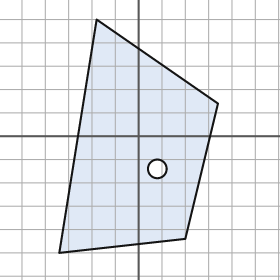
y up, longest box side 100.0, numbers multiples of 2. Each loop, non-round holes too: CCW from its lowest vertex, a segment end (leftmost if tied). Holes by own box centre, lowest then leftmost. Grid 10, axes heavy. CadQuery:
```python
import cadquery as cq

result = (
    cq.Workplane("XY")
    .moveTo(-34.0, -50.0)
    .lineTo(20.0, -44.0)
    .lineTo(34.0, 14.0)
    .lineTo(-18.0, 50.0)
    .close()
    .moveTo(8.0, -14.0)
    .circle(4.0)
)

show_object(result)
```